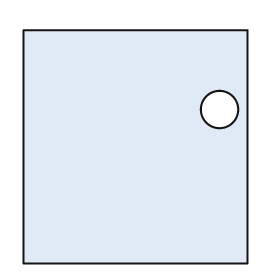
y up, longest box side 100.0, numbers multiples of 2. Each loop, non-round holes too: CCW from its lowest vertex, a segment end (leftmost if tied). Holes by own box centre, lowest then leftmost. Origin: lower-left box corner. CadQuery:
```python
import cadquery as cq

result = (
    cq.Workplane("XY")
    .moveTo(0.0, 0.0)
    .lineTo(96.0, 0.0)
    .lineTo(96.0, 100.0)
    .lineTo(0.0, 100.0)
    .close()
    .moveTo(84.0, 66.0)
    .circle(8.0)
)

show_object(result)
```